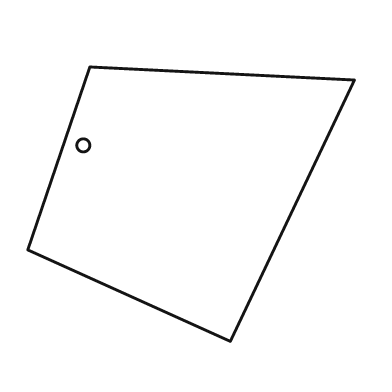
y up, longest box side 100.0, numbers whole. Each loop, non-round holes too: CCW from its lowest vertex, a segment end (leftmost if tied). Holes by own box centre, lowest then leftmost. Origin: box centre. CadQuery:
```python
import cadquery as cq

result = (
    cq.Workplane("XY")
    .moveTo(12.0, -42.0)
    .lineTo(50.0, 38.0)
    .lineTo(-31.0, 42.0)
    .lineTo(-50.0, -14.0)
    .close()
    .moveTo(-33.0, 18.0)
    .circle(2.0)
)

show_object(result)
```